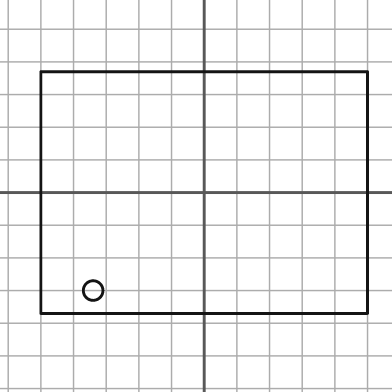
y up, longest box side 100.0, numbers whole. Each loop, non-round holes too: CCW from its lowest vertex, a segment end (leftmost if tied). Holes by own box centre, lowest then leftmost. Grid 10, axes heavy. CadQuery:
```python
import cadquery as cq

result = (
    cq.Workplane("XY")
    .moveTo(-50.0, -37.0)
    .lineTo(50.0, -37.0)
    .lineTo(50.0, 37.0)
    .lineTo(-50.0, 37.0)
    .close()
    .moveTo(-34.0, -30.0)
    .circle(3.0)
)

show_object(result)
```